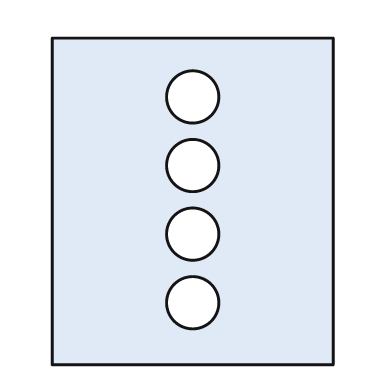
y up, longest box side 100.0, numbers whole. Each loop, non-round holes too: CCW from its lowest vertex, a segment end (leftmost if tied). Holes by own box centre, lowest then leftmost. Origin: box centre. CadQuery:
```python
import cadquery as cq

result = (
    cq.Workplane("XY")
    .moveTo(-43.0, -50.0)
    .lineTo(43.0, -50.0)
    .lineTo(43.0, 50.0)
    .lineTo(-43.0, 50.0)
    .close()
    .moveTo(0.0, -31.0)
    .circle(8.0)
    .moveTo(0.0, -10.0)
    .circle(8.0)
    .moveTo(0.0, 11.0)
    .circle(8.0)
    .moveTo(0.0, 32.0)
    .circle(8.0)
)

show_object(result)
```